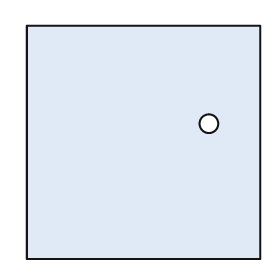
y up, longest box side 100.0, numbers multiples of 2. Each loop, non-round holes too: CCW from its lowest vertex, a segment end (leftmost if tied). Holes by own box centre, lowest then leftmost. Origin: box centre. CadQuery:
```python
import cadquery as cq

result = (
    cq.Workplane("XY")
    .moveTo(-50.0, -50.0)
    .lineTo(50.0, -50.0)
    .lineTo(50.0, 50.0)
    .lineTo(-50.0, 50.0)
    .close()
    .moveTo(28.0, 8.0)
    .circle(4.0)
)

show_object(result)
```